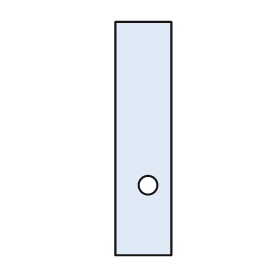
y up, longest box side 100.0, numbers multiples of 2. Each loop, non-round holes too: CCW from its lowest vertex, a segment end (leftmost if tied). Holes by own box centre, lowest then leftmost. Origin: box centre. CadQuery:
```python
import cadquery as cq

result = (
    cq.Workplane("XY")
    .moveTo(-12.0, -50.0)
    .lineTo(12.0, -50.0)
    .lineTo(12.0, 50.0)
    .lineTo(-12.0, 50.0)
    .close()
    .moveTo(2.0, -20.0)
    .circle(4.0)
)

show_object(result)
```